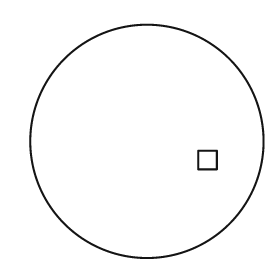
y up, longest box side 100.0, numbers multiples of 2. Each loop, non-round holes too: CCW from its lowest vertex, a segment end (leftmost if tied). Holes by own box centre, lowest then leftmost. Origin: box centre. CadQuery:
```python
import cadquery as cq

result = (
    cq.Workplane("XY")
    .moveTo(0.0, 0.0)
    .circle(50.0)
    .moveTo(22.0, -12.0)
    .lineTo(30.0, -12.0)
    .lineTo(30.0, -4.0)
    .lineTo(22.0, -4.0)
    .close()
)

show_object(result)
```